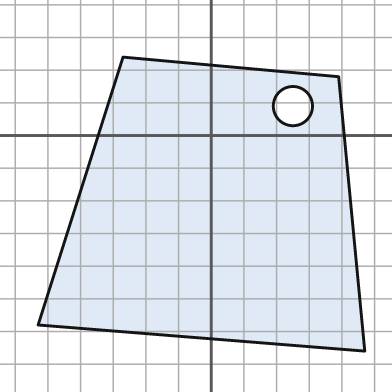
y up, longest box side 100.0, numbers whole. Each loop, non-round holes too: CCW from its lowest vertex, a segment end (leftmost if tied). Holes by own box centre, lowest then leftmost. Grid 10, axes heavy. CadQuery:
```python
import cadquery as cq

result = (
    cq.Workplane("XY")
    .moveTo(47.0, -66.0)
    .lineTo(39.0, 18.0)
    .lineTo(-27.0, 24.0)
    .lineTo(-53.0, -58.0)
    .close()
    .moveTo(25.0, 9.0)
    .circle(6.0)
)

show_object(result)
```